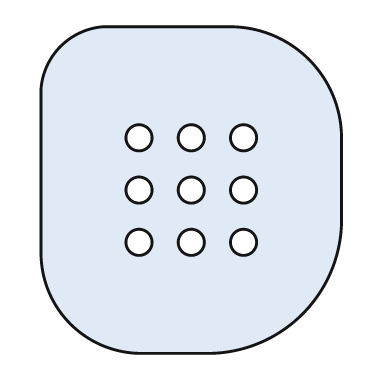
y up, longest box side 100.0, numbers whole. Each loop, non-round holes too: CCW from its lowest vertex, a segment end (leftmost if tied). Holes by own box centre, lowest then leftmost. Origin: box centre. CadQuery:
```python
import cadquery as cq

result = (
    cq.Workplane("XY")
    .moveTo(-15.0, -50.0)
    .lineTo(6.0, -50.0)
    .threePointArc((34.0, -38.0), (46.0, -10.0))
    .lineTo(46.0, 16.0)
    .threePointArc((36.0, 40.0), (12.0, 50.0))
    .lineTo(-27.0, 50.0)
    .threePointArc((-40.0, 44.0), (-46.0, 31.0))
    .lineTo(-46.0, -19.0)
    .threePointArc((-37.0, -41.0), (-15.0, -50.0))
    .close()
    .moveTo(-16.0, -16.0)
    .circle(4.0)
    .moveTo(0.0, -16.0)
    .circle(4.0)
    .moveTo(16.0, -16.0)
    .circle(4.0)
    .moveTo(-16.0, 0.0)
    .circle(4.0)
    .moveTo(0.0, 0.0)
    .circle(4.0)
    .moveTo(16.0, 0.0)
    .circle(4.0)
    .moveTo(-16.0, 16.0)
    .circle(4.0)
    .moveTo(0.0, 16.0)
    .circle(4.0)
    .moveTo(16.0, 16.0)
    .circle(4.0)
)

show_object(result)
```